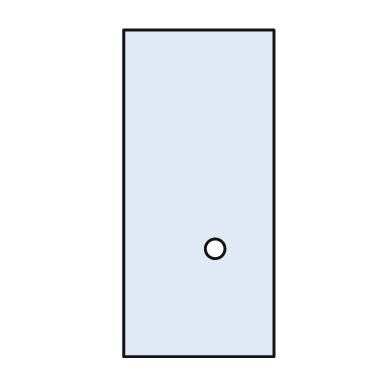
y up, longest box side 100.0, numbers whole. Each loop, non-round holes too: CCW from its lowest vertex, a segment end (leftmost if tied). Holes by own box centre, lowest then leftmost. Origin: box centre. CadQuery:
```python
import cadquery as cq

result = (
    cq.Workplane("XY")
    .moveTo(-23.0, -50.0)
    .lineTo(23.0, -50.0)
    .lineTo(23.0, 50.0)
    .lineTo(-23.0, 50.0)
    .close()
    .moveTo(5.0, -17.0)
    .circle(3.0)
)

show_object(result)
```